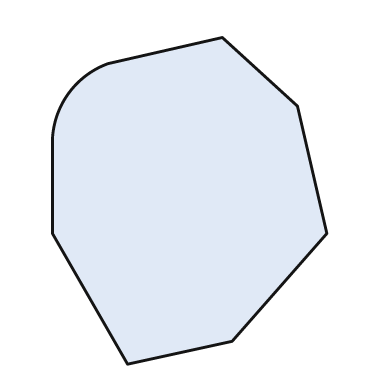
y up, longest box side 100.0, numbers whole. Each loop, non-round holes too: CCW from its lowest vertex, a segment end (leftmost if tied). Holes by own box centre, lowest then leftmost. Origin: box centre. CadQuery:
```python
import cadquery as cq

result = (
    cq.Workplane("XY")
    .moveTo(-19.0, -50.0)
    .lineTo(13.0, -43.0)
    .lineTo(42.0, -10.0)
    .lineTo(33.0, 29.0)
    .lineTo(10.0, 50.0)
    .lineTo(-25.0, 42.0)
    .threePointArc((-37.0, 33.0), (-42.0, 19.0))
    .lineTo(-42.0, -10.0)
    .close()
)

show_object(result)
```